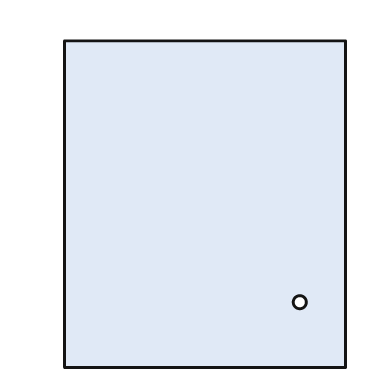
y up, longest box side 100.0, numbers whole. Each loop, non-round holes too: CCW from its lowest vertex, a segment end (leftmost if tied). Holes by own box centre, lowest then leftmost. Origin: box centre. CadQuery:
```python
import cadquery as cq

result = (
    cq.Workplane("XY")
    .moveTo(-43.0, -50.0)
    .lineTo(43.0, -50.0)
    .lineTo(43.0, 50.0)
    .lineTo(-43.0, 50.0)
    .close()
    .moveTo(29.0, -30.0)
    .circle(2.0)
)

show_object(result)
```